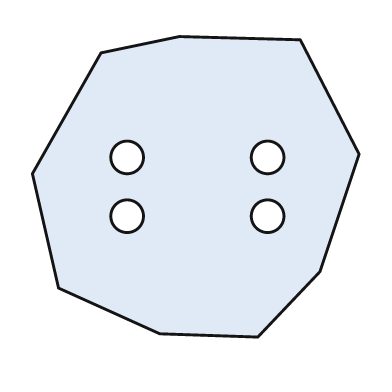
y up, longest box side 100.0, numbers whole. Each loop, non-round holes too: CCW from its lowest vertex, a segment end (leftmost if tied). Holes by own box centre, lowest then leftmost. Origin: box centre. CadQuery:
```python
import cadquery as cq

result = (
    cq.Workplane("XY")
    .moveTo(19.0, -46.0)
    .lineTo(38.0, -26.0)
    .lineTo(50.0, 10.0)
    .lineTo(32.0, 45.0)
    .lineTo(-5.0, 46.0)
    .lineTo(-29.0, 41.0)
    .lineTo(-50.0, 4.0)
    .lineTo(-42.0, -31.0)
    .lineTo(-11.0, -45.0)
    .close()
    .moveTo(-21.0, -9.0)
    .circle(5.0)
    .moveTo(22.0, -9.0)
    .circle(5.0)
    .moveTo(-21.0, 9.0)
    .circle(5.0)
    .moveTo(22.0, 9.0)
    .circle(5.0)
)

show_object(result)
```